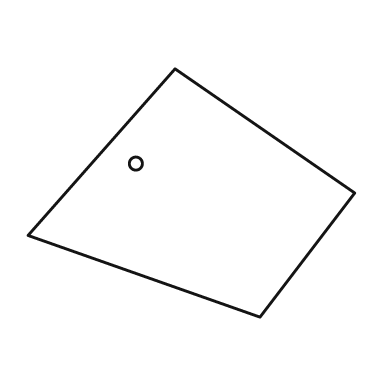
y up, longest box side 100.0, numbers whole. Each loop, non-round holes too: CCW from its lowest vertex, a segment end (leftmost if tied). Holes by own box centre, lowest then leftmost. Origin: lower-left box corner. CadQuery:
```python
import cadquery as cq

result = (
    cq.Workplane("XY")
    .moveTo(71.0, 0.0)
    .lineTo(100.0, 38.0)
    .lineTo(45.0, 76.0)
    .lineTo(0.0, 25.0)
    .close()
    .moveTo(33.0, 47.0)
    .circle(2.0)
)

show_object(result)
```